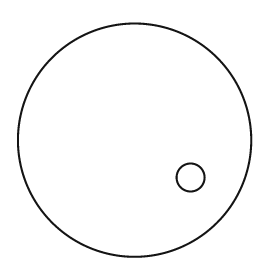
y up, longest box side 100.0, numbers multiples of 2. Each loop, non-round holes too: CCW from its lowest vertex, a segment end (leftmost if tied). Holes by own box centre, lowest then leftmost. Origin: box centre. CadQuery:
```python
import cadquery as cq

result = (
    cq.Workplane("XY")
    .moveTo(0.0, 0.0)
    .circle(50.0)
    .moveTo(24.0, -16.0)
    .circle(6.0)
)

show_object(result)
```